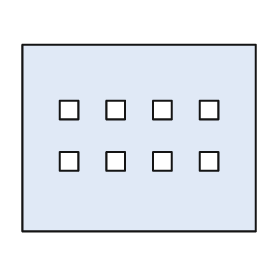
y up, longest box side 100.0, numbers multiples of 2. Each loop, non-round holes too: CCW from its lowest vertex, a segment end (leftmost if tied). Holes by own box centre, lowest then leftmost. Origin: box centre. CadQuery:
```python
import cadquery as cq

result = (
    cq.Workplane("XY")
    .moveTo(-50.0, -40.0)
    .lineTo(50.0, -40.0)
    .lineTo(50.0, 40.0)
    .lineTo(-50.0, 40.0)
    .close()
    .moveTo(-34.0, -14.0)
    .lineTo(-26.0, -14.0)
    .lineTo(-26.0, -6.0)
    .lineTo(-34.0, -6.0)
    .close()
    .moveTo(-14.0, -14.0)
    .lineTo(-6.0, -14.0)
    .lineTo(-6.0, -6.0)
    .lineTo(-14.0, -6.0)
    .close()
    .moveTo(6.0, -14.0)
    .lineTo(14.0, -14.0)
    .lineTo(14.0, -6.0)
    .lineTo(6.0, -6.0)
    .close()
    .moveTo(26.0, -14.0)
    .lineTo(34.0, -14.0)
    .lineTo(34.0, -6.0)
    .lineTo(26.0, -6.0)
    .close()
    .moveTo(-34.0, 8.0)
    .lineTo(-26.0, 8.0)
    .lineTo(-26.0, 16.0)
    .lineTo(-34.0, 16.0)
    .close()
    .moveTo(-14.0, 8.0)
    .lineTo(-6.0, 8.0)
    .lineTo(-6.0, 16.0)
    .lineTo(-14.0, 16.0)
    .close()
    .moveTo(6.0, 8.0)
    .lineTo(14.0, 8.0)
    .lineTo(14.0, 16.0)
    .lineTo(6.0, 16.0)
    .close()
    .moveTo(26.0, 8.0)
    .lineTo(34.0, 8.0)
    .lineTo(34.0, 16.0)
    .lineTo(26.0, 16.0)
    .close()
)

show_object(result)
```